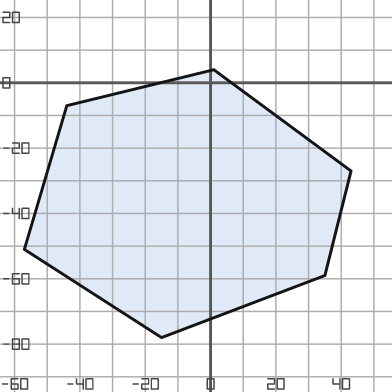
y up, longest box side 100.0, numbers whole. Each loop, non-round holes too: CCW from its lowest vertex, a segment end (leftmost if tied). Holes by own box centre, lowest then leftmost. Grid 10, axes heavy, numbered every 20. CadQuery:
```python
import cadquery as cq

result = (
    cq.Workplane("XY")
    .moveTo(-15.0, -78.0)
    .lineTo(35.0, -59.0)
    .lineTo(43.0, -27.0)
    .lineTo(1.0, 4.0)
    .lineTo(-44.0, -7.0)
    .lineTo(-57.0, -51.0)
    .close()
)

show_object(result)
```